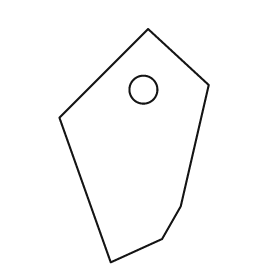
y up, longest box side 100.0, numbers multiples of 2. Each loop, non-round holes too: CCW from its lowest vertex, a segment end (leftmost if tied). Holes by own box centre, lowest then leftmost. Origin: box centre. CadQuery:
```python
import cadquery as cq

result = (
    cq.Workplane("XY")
    .moveTo(-10.0, -50.0)
    .lineTo(12.0, -40.0)
    .lineTo(20.0, -26.0)
    .lineTo(32.0, 26.0)
    .lineTo(6.0, 50.0)
    .lineTo(-32.0, 12.0)
    .close()
    .moveTo(4.0, 24.0)
    .circle(6.0)
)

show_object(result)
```